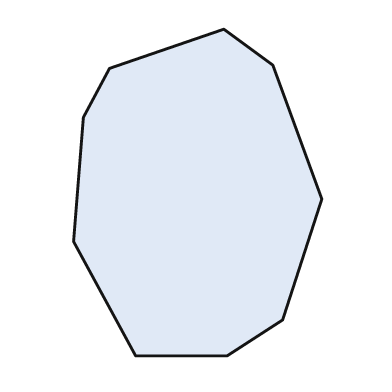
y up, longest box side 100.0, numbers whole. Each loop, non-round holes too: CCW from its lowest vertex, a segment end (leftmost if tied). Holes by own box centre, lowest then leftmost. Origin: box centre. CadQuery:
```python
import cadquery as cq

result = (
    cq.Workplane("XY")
    .moveTo(-19.0, -50.0)
    .lineTo(9.0, -50.0)
    .lineTo(26.0, -39.0)
    .lineTo(38.0, -2.0)
    .lineTo(23.0, 39.0)
    .lineTo(8.0, 50.0)
    .lineTo(-27.0, 38.0)
    .lineTo(-35.0, 23.0)
    .lineTo(-38.0, -15.0)
    .close()
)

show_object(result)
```